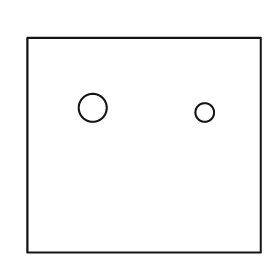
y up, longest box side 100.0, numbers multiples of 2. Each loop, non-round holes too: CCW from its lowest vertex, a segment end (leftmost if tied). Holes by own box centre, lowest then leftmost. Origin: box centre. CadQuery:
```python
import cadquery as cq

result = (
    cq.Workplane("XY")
    .moveTo(-50.0, -46.0)
    .lineTo(50.0, -46.0)
    .lineTo(50.0, 46.0)
    .lineTo(-50.0, 46.0)
    .close()
    .moveTo(26.0, 14.0)
    .circle(4.0)
    .moveTo(-22.0, 16.0)
    .circle(6.0)
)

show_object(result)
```